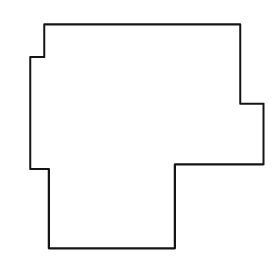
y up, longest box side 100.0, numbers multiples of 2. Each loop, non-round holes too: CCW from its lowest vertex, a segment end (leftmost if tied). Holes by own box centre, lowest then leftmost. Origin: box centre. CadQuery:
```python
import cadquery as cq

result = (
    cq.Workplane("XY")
    .moveTo(-42.0, -48.0)
    .lineTo(12.0, -48.0)
    .lineTo(12.0, -12.0)
    .lineTo(50.0, -12.0)
    .lineTo(50.0, 14.0)
    .lineTo(40.0, 14.0)
    .lineTo(40.0, 48.0)
    .lineTo(-44.0, 48.0)
    .lineTo(-44.0, 34.0)
    .lineTo(-50.0, 34.0)
    .lineTo(-50.0, -14.0)
    .lineTo(-42.0, -14.0)
    .close()
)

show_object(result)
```